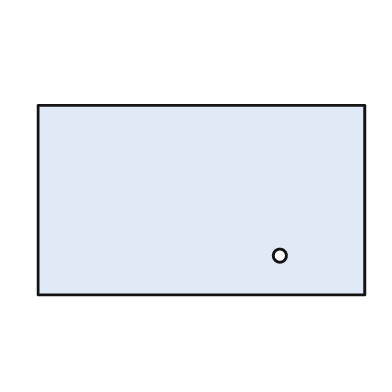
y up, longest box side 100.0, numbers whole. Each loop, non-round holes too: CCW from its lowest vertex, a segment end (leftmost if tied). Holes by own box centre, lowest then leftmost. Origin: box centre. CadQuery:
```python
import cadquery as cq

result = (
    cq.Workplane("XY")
    .moveTo(-50.0, -29.0)
    .lineTo(50.0, -29.0)
    .lineTo(50.0, 29.0)
    .lineTo(-50.0, 29.0)
    .close()
    .moveTo(24.0, -17.0)
    .circle(2.0)
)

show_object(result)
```